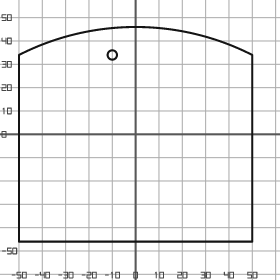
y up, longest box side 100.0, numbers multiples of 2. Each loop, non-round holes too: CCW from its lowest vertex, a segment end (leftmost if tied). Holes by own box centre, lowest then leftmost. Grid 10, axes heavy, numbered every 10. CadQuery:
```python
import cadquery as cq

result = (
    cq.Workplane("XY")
    .moveTo(-50.0, -46.0)
    .lineTo(50.0, -46.0)
    .lineTo(50.0, 34.0)
    .threePointArc((0.0, 46.0), (-50.0, 34.0))
    .close()
    .moveTo(-10.0, 34.0)
    .circle(2.0)
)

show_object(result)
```